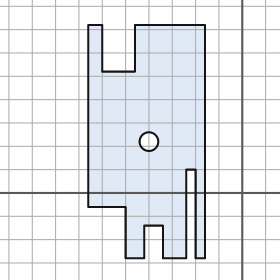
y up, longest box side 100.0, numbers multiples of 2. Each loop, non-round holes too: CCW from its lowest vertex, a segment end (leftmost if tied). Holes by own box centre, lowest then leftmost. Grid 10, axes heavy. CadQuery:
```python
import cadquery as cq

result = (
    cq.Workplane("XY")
    .moveTo(-50.0, -28.0)
    .lineTo(-42.0, -28.0)
    .lineTo(-42.0, -14.0)
    .lineTo(-34.0, -14.0)
    .lineTo(-34.0, -28.0)
    .lineTo(-24.0, -28.0)
    .lineTo(-24.0, 10.0)
    .lineTo(-20.0, 10.0)
    .lineTo(-20.0, -28.0)
    .lineTo(-16.0, -28.0)
    .lineTo(-16.0, 72.0)
    .lineTo(-46.0, 72.0)
    .lineTo(-46.0, 52.0)
    .lineTo(-60.0, 52.0)
    .lineTo(-60.0, 72.0)
    .lineTo(-66.0, 72.0)
    .lineTo(-66.0, -6.0)
    .lineTo(-50.0, -6.0)
    .close()
    .moveTo(-40.0, 22.0)
    .circle(4.0)
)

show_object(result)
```